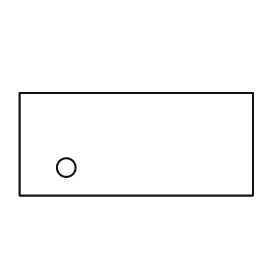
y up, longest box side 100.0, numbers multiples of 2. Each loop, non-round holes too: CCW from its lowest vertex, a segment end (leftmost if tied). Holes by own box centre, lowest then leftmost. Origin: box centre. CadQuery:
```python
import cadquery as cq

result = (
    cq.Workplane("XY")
    .moveTo(-50.0, -22.0)
    .lineTo(50.0, -22.0)
    .lineTo(50.0, 22.0)
    .lineTo(-50.0, 22.0)
    .close()
    .moveTo(-30.0, -10.0)
    .circle(4.0)
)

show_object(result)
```